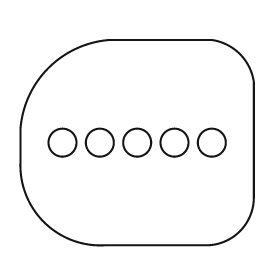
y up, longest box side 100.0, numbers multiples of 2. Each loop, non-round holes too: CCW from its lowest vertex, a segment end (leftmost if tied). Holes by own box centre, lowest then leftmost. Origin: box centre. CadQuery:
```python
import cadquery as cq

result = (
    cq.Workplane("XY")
    .moveTo(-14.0, -44.0)
    .lineTo(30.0, -44.0)
    .threePointArc((44.0, -38.0), (50.0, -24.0))
    .lineTo(50.0, 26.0)
    .threePointArc((44.0, 38.0), (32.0, 44.0))
    .lineTo(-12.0, 44.0)
    .threePointArc((-38.0, 32.0), (-50.0, 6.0))
    .lineTo(-50.0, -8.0)
    .threePointArc((-40.0, -34.0), (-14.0, -44.0))
    .close()
    .moveTo(-32.0, 0.0)
    .circle(6.0)
    .moveTo(-16.0, 0.0)
    .circle(6.0)
    .moveTo(0.0, 0.0)
    .circle(6.0)
    .moveTo(16.0, 0.0)
    .circle(6.0)
    .moveTo(32.0, 0.0)
    .circle(6.0)
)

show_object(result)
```